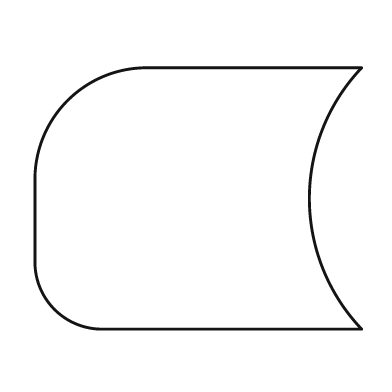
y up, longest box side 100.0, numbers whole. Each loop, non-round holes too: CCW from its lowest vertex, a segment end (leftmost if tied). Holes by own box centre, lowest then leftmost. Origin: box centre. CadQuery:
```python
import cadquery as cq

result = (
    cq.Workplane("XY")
    .moveTo(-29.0, -40.0)
    .lineTo(50.0, -40.0)
    .threePointArc((34.0, 0.0), (50.0, 40.0))
    .lineTo(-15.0, 40.0)
    .threePointArc((-40.0, 30.0), (-50.0, 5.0))
    .lineTo(-50.0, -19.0)
    .threePointArc((-44.0, -34.0), (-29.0, -40.0))
    .close()
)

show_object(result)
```